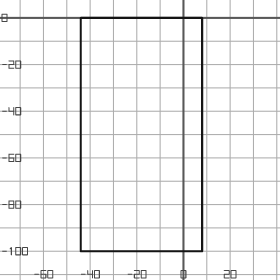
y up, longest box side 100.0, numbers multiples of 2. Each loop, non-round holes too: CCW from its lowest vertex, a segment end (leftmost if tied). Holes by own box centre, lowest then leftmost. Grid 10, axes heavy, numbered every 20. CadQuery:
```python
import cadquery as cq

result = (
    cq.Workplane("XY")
    .moveTo(-44.0, -100.0)
    .lineTo(8.0, -100.0)
    .lineTo(8.0, 0.0)
    .lineTo(-44.0, 0.0)
    .close()
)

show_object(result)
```